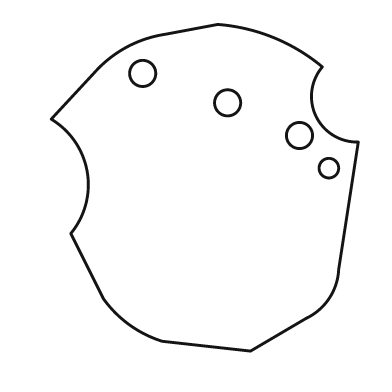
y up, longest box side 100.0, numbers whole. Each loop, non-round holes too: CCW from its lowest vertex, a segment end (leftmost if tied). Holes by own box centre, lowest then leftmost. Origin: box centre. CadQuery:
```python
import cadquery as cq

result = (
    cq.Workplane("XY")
    .moveTo(14.0, -50.0)
    .lineTo(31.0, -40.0)
    .threePointArc((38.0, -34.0), (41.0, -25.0))
    .lineTo(47.0, 14.0)
    .threePointArc((34.0, 22.0), (36.0, 37.0))
    .threePointArc((21.0, 46.0), (4.0, 50.0))
    .lineTo(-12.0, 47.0)
    .threePointArc((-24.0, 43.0), (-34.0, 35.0))
    .lineTo(-47.0, 21.0)
    .threePointArc((-36.0, 5.0), (-41.0, -14.0))
    .lineTo(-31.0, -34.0)
    .threePointArc((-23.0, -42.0), (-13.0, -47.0))
    .close()
    .moveTo(38.0, 6.0)
    .circle(3.0)
    .moveTo(29.0, 16.0)
    .circle(4.0)
    .moveTo(7.0, 26.0)
    .circle(4.0)
    .moveTo(-19.0, 35.0)
    .circle(4.0)
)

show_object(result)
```